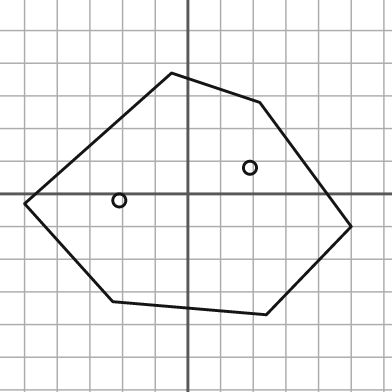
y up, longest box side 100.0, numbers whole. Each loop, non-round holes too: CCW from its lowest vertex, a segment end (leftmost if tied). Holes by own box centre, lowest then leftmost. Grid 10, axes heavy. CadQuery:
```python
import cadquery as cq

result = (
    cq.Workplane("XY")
    .moveTo(24.0, -37.0)
    .lineTo(50.0, -10.0)
    .lineTo(22.0, 28.0)
    .lineTo(-5.0, 37.0)
    .lineTo(-50.0, -3.0)
    .lineTo(-23.0, -33.0)
    .close()
    .moveTo(-21.0, -2.0)
    .circle(2.0)
    .moveTo(19.0, 8.0)
    .circle(2.0)
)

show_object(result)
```